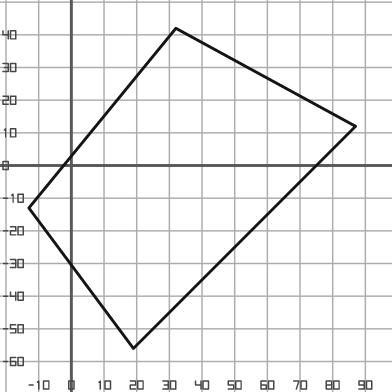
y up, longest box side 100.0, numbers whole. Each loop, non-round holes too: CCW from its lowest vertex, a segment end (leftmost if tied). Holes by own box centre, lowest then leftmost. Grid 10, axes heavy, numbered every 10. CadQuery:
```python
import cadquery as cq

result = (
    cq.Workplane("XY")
    .moveTo(19.0, -56.0)
    .lineTo(87.0, 12.0)
    .lineTo(32.0, 42.0)
    .lineTo(-13.0, -13.0)
    .close()
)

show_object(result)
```